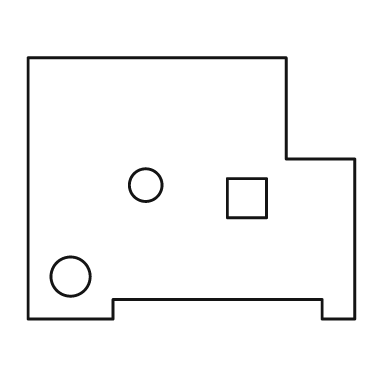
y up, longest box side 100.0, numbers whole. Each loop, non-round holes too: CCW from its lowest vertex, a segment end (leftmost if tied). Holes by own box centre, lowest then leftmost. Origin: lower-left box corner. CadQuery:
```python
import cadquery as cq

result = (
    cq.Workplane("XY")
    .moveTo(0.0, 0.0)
    .lineTo(26.0, 0.0)
    .lineTo(26.0, 6.0)
    .lineTo(90.0, 6.0)
    .lineTo(90.0, 0.0)
    .lineTo(100.0, 0.0)
    .lineTo(100.0, 49.0)
    .lineTo(79.0, 49.0)
    .lineTo(79.0, 80.0)
    .lineTo(0.0, 80.0)
    .close()
    .moveTo(13.0, 13.0)
    .circle(6.0)
    .moveTo(61.0, 31.0)
    .lineTo(73.0, 31.0)
    .lineTo(73.0, 43.0)
    .lineTo(61.0, 43.0)
    .close()
    .moveTo(36.0, 41.0)
    .circle(5.0)
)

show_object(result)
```